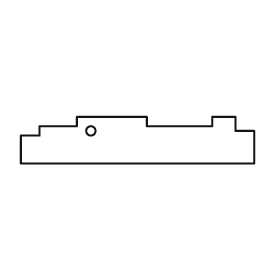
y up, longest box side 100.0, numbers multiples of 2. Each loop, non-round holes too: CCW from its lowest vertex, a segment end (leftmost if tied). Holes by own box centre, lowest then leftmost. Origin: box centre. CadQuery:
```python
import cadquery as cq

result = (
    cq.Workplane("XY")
    .moveTo(-50.0, -10.0)
    .lineTo(50.0, -10.0)
    .lineTo(50.0, 4.0)
    .lineTo(42.0, 4.0)
    .lineTo(42.0, 10.0)
    .lineTo(32.0, 10.0)
    .lineTo(32.0, 6.0)
    .lineTo(4.0, 6.0)
    .lineTo(4.0, 10.0)
    .lineTo(-26.0, 10.0)
    .lineTo(-26.0, 6.0)
    .lineTo(-42.0, 6.0)
    .lineTo(-42.0, 2.0)
    .lineTo(-50.0, 2.0)
    .close()
    .moveTo(-20.0, 4.0)
    .circle(2.0)
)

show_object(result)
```